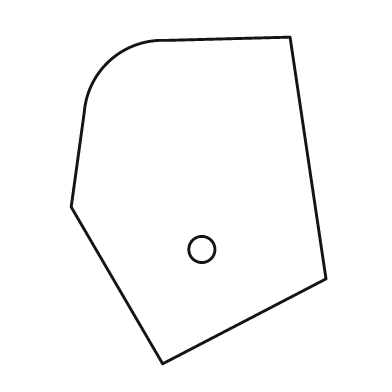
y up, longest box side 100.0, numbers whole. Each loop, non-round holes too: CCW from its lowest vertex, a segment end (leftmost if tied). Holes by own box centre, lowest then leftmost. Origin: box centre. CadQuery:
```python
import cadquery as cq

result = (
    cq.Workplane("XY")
    .moveTo(-11.0, -50.0)
    .lineTo(39.0, -24.0)
    .lineTo(28.0, 50.0)
    .lineTo(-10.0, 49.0)
    .threePointArc((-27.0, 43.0), (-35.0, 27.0))
    .lineTo(-39.0, -2.0)
    .close()
    .moveTo(1.0, -15.0)
    .circle(4.0)
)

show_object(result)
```